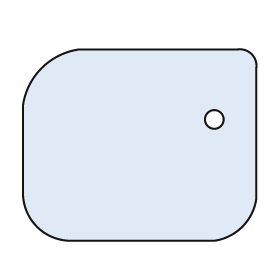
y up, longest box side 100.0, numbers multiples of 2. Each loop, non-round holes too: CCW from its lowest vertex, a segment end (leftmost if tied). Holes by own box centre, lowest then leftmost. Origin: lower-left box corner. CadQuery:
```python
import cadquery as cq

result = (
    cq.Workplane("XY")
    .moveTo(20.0, 0.0)
    .lineTo(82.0, 0.0)
    .threePointArc((94.0, 6.0), (100.0, 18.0))
    .lineTo(100.0, 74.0)
    .threePointArc((98.0, 80.0), (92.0, 82.0))
    .lineTo(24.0, 82.0)
    .threePointArc((8.0, 74.0), (0.0, 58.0))
    .lineTo(0.0, 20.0)
    .threePointArc((6.0, 6.0), (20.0, 0.0))
    .close()
    .moveTo(82.0, 52.0)
    .circle(4.0)
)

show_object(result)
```